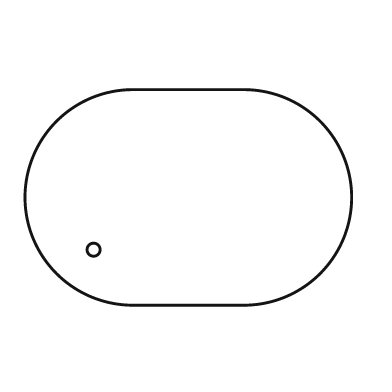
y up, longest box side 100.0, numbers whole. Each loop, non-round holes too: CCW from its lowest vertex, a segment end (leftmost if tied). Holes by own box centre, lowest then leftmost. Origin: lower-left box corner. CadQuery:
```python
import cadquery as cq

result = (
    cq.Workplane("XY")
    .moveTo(33.0, 0.0)
    .lineTo(67.0, 0.0)
    .threePointArc((100.0, 33.0), (67.0, 66.0))
    .lineTo(33.0, 66.0)
    .threePointArc((0.0, 33.0), (33.0, 0.0))
    .close()
    .moveTo(21.0, 17.0)
    .circle(2.0)
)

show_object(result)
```